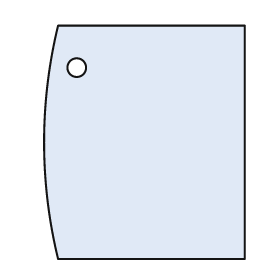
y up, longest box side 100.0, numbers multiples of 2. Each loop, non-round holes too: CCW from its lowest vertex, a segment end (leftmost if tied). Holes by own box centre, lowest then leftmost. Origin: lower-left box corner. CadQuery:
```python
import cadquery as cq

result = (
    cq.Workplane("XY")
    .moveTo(6.0, 0.0)
    .lineTo(86.0, 0.0)
    .lineTo(86.0, 100.0)
    .lineTo(6.0, 100.0)
    .threePointArc((0.0, 50.0), (6.0, 0.0))
    .close()
    .moveTo(14.0, 82.0)
    .circle(4.0)
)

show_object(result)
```